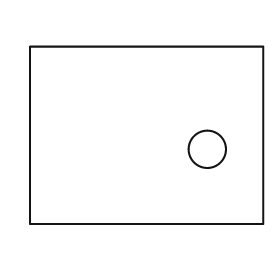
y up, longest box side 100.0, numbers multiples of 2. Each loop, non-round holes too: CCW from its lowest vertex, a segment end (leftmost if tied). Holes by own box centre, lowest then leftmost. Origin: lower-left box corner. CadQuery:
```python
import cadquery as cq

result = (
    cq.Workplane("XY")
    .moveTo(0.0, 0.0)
    .lineTo(100.0, 0.0)
    .lineTo(100.0, 76.0)
    .lineTo(0.0, 76.0)
    .close()
    .moveTo(76.0, 32.0)
    .circle(8.0)
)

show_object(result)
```